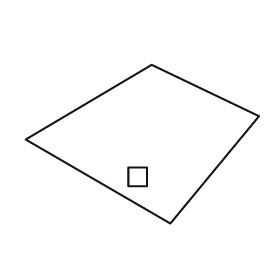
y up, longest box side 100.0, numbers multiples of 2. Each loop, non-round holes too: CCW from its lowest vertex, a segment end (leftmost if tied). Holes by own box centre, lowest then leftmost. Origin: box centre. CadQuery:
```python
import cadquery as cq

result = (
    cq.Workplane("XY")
    .moveTo(12.0, -34.0)
    .lineTo(50.0, 12.0)
    .lineTo(4.0, 34.0)
    .lineTo(-50.0, 2.0)
    .close()
    .moveTo(-6.0, -18.0)
    .lineTo(2.0, -18.0)
    .lineTo(2.0, -10.0)
    .lineTo(-6.0, -10.0)
    .close()
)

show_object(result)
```